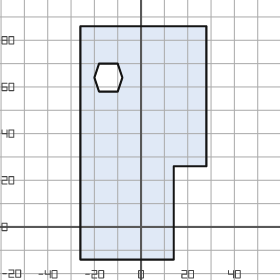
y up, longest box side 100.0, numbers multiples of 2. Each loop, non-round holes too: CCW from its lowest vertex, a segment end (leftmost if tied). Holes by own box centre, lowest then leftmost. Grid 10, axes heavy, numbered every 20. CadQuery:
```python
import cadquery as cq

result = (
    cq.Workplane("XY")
    .moveTo(-26.0, -14.0)
    .lineTo(14.0, -14.0)
    .lineTo(14.0, 26.0)
    .lineTo(28.0, 26.0)
    .lineTo(28.0, 86.0)
    .lineTo(-26.0, 86.0)
    .close()
    .moveTo(-18.0, 58.0)
    .lineTo(-10.0, 58.0)
    .lineTo(-8.0, 64.0)
    .lineTo(-10.0, 70.0)
    .lineTo(-18.0, 70.0)
    .lineTo(-20.0, 64.0)
    .close()
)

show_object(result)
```